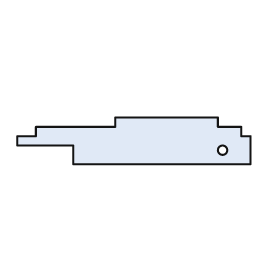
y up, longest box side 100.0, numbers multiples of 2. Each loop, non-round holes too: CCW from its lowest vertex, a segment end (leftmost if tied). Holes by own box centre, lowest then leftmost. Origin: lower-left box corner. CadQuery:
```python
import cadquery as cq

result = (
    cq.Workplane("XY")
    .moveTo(24.0, 0.0)
    .lineTo(100.0, 0.0)
    .lineTo(100.0, 12.0)
    .lineTo(96.0, 12.0)
    .lineTo(96.0, 16.0)
    .lineTo(86.0, 16.0)
    .lineTo(86.0, 20.0)
    .lineTo(42.0, 20.0)
    .lineTo(42.0, 16.0)
    .lineTo(8.0, 16.0)
    .lineTo(8.0, 12.0)
    .lineTo(0.0, 12.0)
    .lineTo(0.0, 8.0)
    .lineTo(24.0, 8.0)
    .close()
    .moveTo(88.0, 6.0)
    .circle(2.0)
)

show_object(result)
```